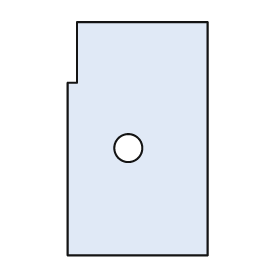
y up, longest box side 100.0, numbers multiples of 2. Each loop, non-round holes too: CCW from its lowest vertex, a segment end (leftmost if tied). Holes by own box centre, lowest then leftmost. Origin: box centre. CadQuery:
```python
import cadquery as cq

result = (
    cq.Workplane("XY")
    .moveTo(-30.0, -50.0)
    .lineTo(30.0, -50.0)
    .lineTo(30.0, 50.0)
    .lineTo(-26.0, 50.0)
    .lineTo(-26.0, 24.0)
    .lineTo(-30.0, 24.0)
    .close()
    .moveTo(-4.0, -4.0)
    .circle(6.0)
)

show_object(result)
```